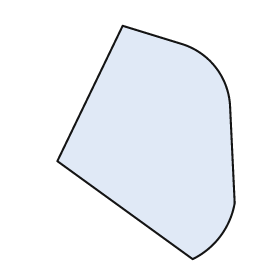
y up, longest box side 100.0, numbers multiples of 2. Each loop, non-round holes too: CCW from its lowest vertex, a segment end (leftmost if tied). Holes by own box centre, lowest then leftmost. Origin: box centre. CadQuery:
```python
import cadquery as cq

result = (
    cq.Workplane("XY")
    .moveTo(20.0, -50.0)
    .threePointArc((32.0, -40.0), (38.0, -26.0))
    .lineTo(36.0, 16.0)
    .threePointArc((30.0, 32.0), (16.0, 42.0))
    .lineTo(-10.0, 50.0)
    .lineTo(-38.0, -8.0)
    .close()
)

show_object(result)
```